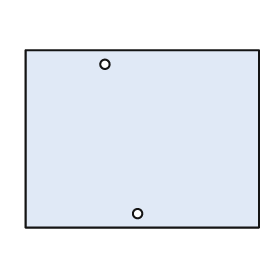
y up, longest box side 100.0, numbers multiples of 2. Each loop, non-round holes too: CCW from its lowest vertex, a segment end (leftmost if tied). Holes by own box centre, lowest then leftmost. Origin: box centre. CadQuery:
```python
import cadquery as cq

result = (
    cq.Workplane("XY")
    .moveTo(-50.0, -38.0)
    .lineTo(50.0, -38.0)
    .lineTo(50.0, 38.0)
    .lineTo(-50.0, 38.0)
    .close()
    .moveTo(-2.0, -32.0)
    .circle(2.0)
    .moveTo(-16.0, 32.0)
    .circle(2.0)
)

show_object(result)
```